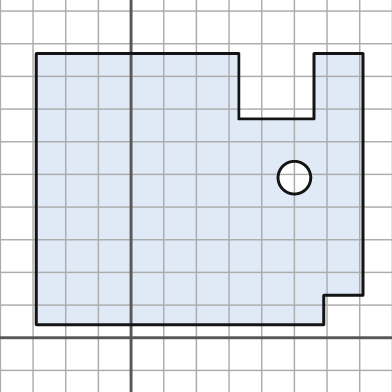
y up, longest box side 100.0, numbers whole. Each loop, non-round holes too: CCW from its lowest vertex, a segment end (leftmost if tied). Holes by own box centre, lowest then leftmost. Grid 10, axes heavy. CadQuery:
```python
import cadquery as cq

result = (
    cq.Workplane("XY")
    .moveTo(-29.0, 4.0)
    .lineTo(59.0, 4.0)
    .lineTo(59.0, 13.0)
    .lineTo(71.0, 13.0)
    .lineTo(71.0, 87.0)
    .lineTo(56.0, 87.0)
    .lineTo(56.0, 67.0)
    .lineTo(33.0, 67.0)
    .lineTo(33.0, 87.0)
    .lineTo(-29.0, 87.0)
    .close()
    .moveTo(50.0, 49.0)
    .circle(5.0)
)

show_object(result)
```